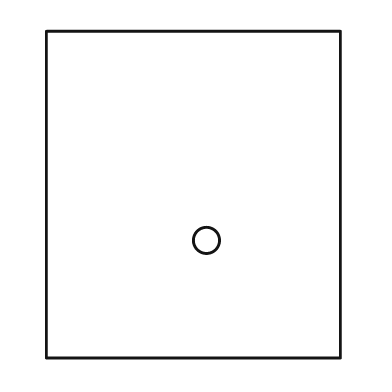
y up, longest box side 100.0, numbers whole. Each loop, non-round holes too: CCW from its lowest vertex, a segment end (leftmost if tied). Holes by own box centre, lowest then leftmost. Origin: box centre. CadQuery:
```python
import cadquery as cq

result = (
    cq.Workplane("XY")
    .moveTo(-45.0, -50.0)
    .lineTo(45.0, -50.0)
    .lineTo(45.0, 50.0)
    .lineTo(-45.0, 50.0)
    .close()
    .moveTo(4.0, -14.0)
    .circle(4.0)
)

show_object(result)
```